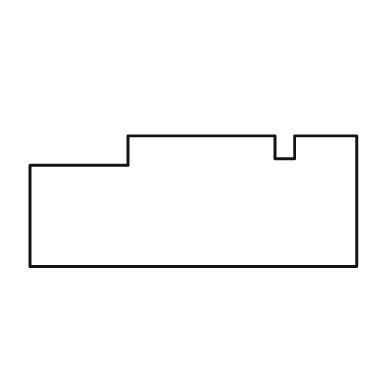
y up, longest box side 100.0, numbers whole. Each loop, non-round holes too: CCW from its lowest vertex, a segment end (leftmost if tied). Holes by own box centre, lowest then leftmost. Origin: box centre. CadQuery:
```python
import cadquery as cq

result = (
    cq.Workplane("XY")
    .moveTo(-50.0, -20.0)
    .lineTo(50.0, -20.0)
    .lineTo(50.0, 20.0)
    .lineTo(31.0, 20.0)
    .lineTo(31.0, 13.0)
    .lineTo(25.0, 13.0)
    .lineTo(25.0, 20.0)
    .lineTo(-20.0, 20.0)
    .lineTo(-20.0, 11.0)
    .lineTo(-50.0, 11.0)
    .close()
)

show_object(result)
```